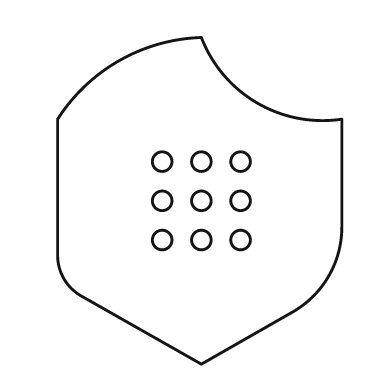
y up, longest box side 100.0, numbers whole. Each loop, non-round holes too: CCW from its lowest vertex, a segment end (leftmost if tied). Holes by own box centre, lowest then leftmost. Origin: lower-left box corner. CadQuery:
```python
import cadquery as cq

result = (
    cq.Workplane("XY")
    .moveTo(44.0, 0.0)
    .lineTo(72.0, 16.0)
    .threePointArc((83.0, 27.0), (87.0, 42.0))
    .lineTo(87.0, 75.0)
    .threePointArc((61.0, 80.0), (44.0, 100.0))
    .threePointArc((19.0, 93.0), (0.0, 75.0))
    .lineTo(0.0, 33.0)
    .threePointArc((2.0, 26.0), (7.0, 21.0))
    .close()
    .moveTo(32.0, 38.0)
    .circle(3.0)
    .moveTo(44.0, 38.0)
    .circle(3.0)
    .moveTo(56.0, 38.0)
    .circle(3.0)
    .moveTo(32.0, 50.0)
    .circle(3.0)
    .moveTo(44.0, 50.0)
    .circle(3.0)
    .moveTo(56.0, 50.0)
    .circle(3.0)
    .moveTo(32.0, 62.0)
    .circle(3.0)
    .moveTo(44.0, 62.0)
    .circle(3.0)
    .moveTo(56.0, 62.0)
    .circle(3.0)
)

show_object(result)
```